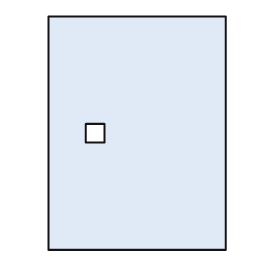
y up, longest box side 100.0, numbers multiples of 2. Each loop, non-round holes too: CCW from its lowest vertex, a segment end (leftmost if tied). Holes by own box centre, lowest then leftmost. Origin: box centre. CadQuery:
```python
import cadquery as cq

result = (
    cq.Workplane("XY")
    .moveTo(-38.0, -50.0)
    .lineTo(38.0, -50.0)
    .lineTo(38.0, 50.0)
    .lineTo(-38.0, 50.0)
    .close()
    .moveTo(-22.0, -4.0)
    .lineTo(-14.0, -4.0)
    .lineTo(-14.0, 4.0)
    .lineTo(-22.0, 4.0)
    .close()
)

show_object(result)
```